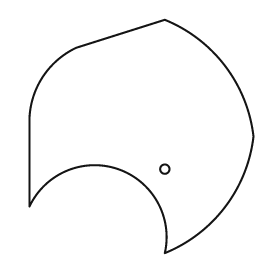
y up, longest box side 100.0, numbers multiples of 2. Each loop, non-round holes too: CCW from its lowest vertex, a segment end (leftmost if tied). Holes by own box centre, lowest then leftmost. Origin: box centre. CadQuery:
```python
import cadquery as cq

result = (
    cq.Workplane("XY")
    .moveTo(10.0, -50.0)
    .threePointArc((36.0, -30.0), (48.0, 0.0))
    .threePointArc((36.0, 30.0), (10.0, 50.0))
    .lineTo(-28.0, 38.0)
    .threePointArc((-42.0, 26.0), (-48.0, 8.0))
    .lineTo(-48.0, -30.0)
    .threePointArc((-10.0, -14.0), (10.0, -50.0))
    .close()
    .moveTo(10.0, -14.0)
    .circle(2.0)
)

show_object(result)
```